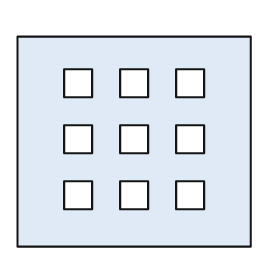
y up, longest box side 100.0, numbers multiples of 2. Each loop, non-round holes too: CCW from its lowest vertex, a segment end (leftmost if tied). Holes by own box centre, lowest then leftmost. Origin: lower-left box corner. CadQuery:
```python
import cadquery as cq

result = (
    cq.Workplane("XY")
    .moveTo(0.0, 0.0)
    .lineTo(100.0, 0.0)
    .lineTo(100.0, 90.0)
    .lineTo(0.0, 90.0)
    .close()
    .moveTo(20.0, 16.0)
    .lineTo(32.0, 16.0)
    .lineTo(32.0, 28.0)
    .lineTo(20.0, 28.0)
    .close()
    .moveTo(44.0, 16.0)
    .lineTo(56.0, 16.0)
    .lineTo(56.0, 28.0)
    .lineTo(44.0, 28.0)
    .close()
    .moveTo(68.0, 16.0)
    .lineTo(80.0, 16.0)
    .lineTo(80.0, 28.0)
    .lineTo(68.0, 28.0)
    .close()
    .moveTo(20.0, 40.0)
    .lineTo(32.0, 40.0)
    .lineTo(32.0, 52.0)
    .lineTo(20.0, 52.0)
    .close()
    .moveTo(44.0, 40.0)
    .lineTo(56.0, 40.0)
    .lineTo(56.0, 52.0)
    .lineTo(44.0, 52.0)
    .close()
    .moveTo(68.0, 40.0)
    .lineTo(80.0, 40.0)
    .lineTo(80.0, 52.0)
    .lineTo(68.0, 52.0)
    .close()
    .moveTo(20.0, 64.0)
    .lineTo(32.0, 64.0)
    .lineTo(32.0, 76.0)
    .lineTo(20.0, 76.0)
    .close()
    .moveTo(44.0, 64.0)
    .lineTo(56.0, 64.0)
    .lineTo(56.0, 76.0)
    .lineTo(44.0, 76.0)
    .close()
    .moveTo(68.0, 64.0)
    .lineTo(80.0, 64.0)
    .lineTo(80.0, 76.0)
    .lineTo(68.0, 76.0)
    .close()
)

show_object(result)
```